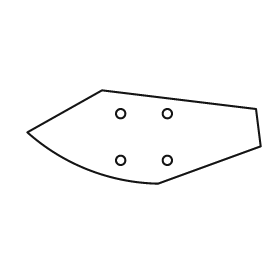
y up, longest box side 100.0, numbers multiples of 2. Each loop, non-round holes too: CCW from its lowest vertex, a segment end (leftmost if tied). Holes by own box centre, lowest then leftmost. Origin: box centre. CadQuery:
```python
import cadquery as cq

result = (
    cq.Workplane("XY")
    .moveTo(6.0, -20.0)
    .lineTo(50.0, -4.0)
    .lineTo(48.0, 12.0)
    .lineTo(-18.0, 20.0)
    .lineTo(-50.0, 2.0)
    .threePointArc((-24.0, -14.0), (6.0, -20.0))
    .close()
    .moveTo(-10.0, -10.0)
    .circle(2.0)
    .moveTo(10.0, -10.0)
    .circle(2.0)
    .moveTo(-10.0, 10.0)
    .circle(2.0)
    .moveTo(10.0, 10.0)
    .circle(2.0)
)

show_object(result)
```